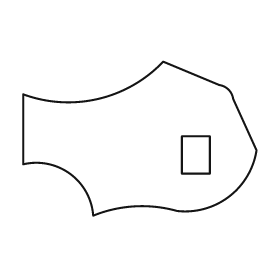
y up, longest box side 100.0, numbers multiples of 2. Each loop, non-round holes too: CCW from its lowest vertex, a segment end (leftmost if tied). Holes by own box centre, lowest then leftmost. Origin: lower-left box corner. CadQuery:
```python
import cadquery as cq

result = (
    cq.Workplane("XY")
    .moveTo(30.0, 0.0)
    .threePointArc((48.0, 4.0), (66.0, 2.0))
    .threePointArc((88.0, 8.0), (100.0, 28.0))
    .lineTo(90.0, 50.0)
    .threePointArc((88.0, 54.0), (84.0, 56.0))
    .lineTo(60.0, 66.0)
    .threePointArc((32.0, 50.0), (0.0, 52.0))
    .lineTo(0.0, 22.0)
    .threePointArc((20.0, 18.0), (30.0, 0.0))
    .close()
    .moveTo(68.0, 18.0)
    .lineTo(80.0, 18.0)
    .lineTo(80.0, 34.0)
    .lineTo(68.0, 34.0)
    .close()
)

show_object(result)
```